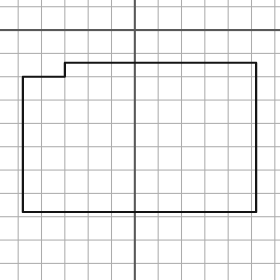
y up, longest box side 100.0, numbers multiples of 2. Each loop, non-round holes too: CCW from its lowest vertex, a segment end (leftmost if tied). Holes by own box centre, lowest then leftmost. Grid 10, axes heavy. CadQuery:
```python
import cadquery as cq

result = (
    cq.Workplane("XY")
    .moveTo(-48.0, -78.0)
    .lineTo(52.0, -78.0)
    .lineTo(52.0, -14.0)
    .lineTo(-30.0, -14.0)
    .lineTo(-30.0, -20.0)
    .lineTo(-48.0, -20.0)
    .close()
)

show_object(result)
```